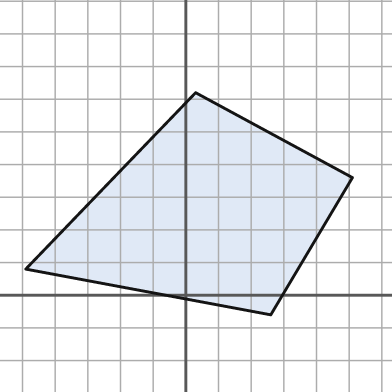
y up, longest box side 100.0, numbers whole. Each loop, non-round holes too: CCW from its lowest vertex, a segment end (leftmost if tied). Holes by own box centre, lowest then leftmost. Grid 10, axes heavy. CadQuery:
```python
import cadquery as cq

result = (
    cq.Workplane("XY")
    .moveTo(26.0, -6.0)
    .lineTo(51.0, 36.0)
    .lineTo(3.0, 62.0)
    .lineTo(-49.0, 8.0)
    .close()
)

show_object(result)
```